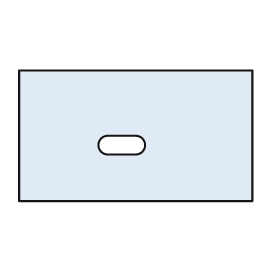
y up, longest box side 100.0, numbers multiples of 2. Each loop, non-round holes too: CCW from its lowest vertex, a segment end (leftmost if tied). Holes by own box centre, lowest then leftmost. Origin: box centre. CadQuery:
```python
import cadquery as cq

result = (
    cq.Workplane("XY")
    .moveTo(-50.0, -28.0)
    .lineTo(50.0, -28.0)
    .lineTo(50.0, 28.0)
    .lineTo(-50.0, 28.0)
    .close()
    .moveTo(-12.0, -8.0)
    .lineTo(0.0, -8.0)
    .threePointArc((4.0, -4.0), (0.0, 0.0))
    .lineTo(-12.0, 0.0)
    .threePointArc((-16.0, -4.0), (-12.0, -8.0))
    .close()
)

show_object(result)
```